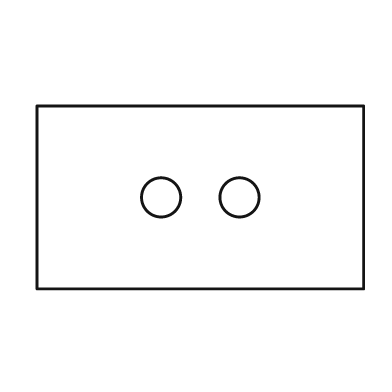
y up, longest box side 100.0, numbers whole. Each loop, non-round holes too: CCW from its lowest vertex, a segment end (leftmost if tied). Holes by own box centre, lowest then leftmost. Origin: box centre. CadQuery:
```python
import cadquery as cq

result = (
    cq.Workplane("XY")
    .moveTo(-50.0, -28.0)
    .lineTo(50.0, -28.0)
    .lineTo(50.0, 28.0)
    .lineTo(-50.0, 28.0)
    .close()
    .moveTo(-12.0, 0.0)
    .circle(6.0)
    .moveTo(12.0, 0.0)
    .circle(6.0)
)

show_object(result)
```